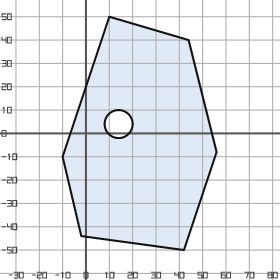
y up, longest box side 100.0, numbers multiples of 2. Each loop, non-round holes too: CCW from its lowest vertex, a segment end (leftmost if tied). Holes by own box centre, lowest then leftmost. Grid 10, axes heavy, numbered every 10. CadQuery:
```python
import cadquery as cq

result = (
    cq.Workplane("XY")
    .moveTo(42.0, -50.0)
    .lineTo(56.0, -8.0)
    .lineTo(44.0, 40.0)
    .lineTo(10.0, 50.0)
    .lineTo(-10.0, -10.0)
    .lineTo(-2.0, -44.0)
    .close()
    .moveTo(14.0, 4.0)
    .circle(6.0)
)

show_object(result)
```